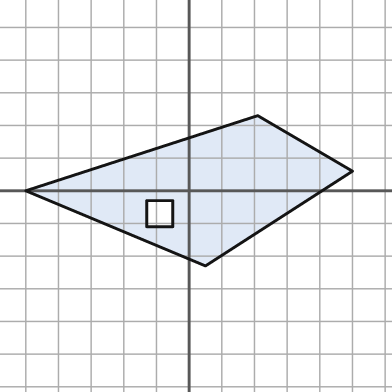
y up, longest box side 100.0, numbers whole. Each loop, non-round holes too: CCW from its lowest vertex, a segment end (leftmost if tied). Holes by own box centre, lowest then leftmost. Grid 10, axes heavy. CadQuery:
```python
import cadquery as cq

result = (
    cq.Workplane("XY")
    .moveTo(5.0, -23.0)
    .lineTo(50.0, 6.0)
    .lineTo(21.0, 23.0)
    .lineTo(-50.0, 0.0)
    .close()
    .moveTo(-13.0, -11.0)
    .lineTo(-5.0, -11.0)
    .lineTo(-5.0, -3.0)
    .lineTo(-13.0, -3.0)
    .close()
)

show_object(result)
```